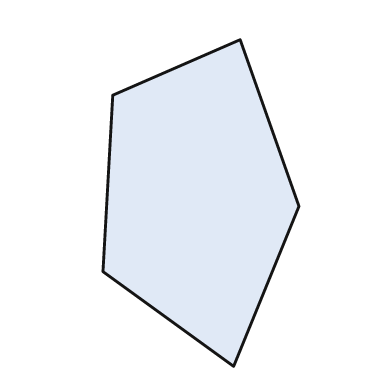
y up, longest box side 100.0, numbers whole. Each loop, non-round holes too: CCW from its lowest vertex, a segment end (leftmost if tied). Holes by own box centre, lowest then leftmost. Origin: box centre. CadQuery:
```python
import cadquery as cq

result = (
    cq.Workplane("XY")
    .moveTo(10.0, -50.0)
    .lineTo(30.0, -1.0)
    .lineTo(12.0, 50.0)
    .lineTo(-27.0, 33.0)
    .lineTo(-30.0, -21.0)
    .close()
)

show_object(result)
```